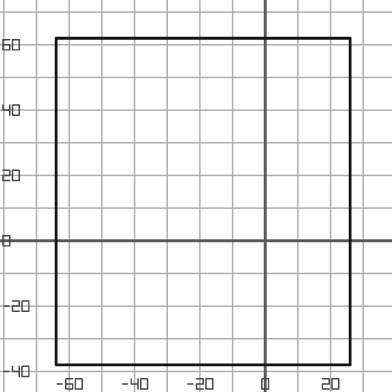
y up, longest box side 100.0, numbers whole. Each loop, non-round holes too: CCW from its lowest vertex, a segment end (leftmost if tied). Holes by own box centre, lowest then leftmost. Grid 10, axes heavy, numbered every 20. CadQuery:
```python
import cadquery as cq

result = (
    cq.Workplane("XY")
    .moveTo(-64.0, -38.0)
    .lineTo(26.0, -38.0)
    .lineTo(26.0, 62.0)
    .lineTo(-64.0, 62.0)
    .close()
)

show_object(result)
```